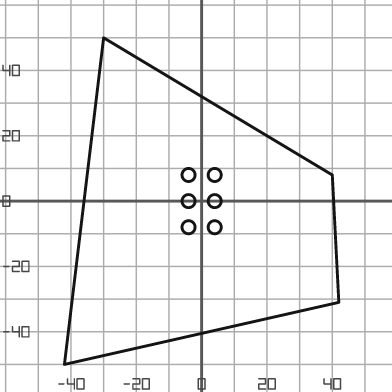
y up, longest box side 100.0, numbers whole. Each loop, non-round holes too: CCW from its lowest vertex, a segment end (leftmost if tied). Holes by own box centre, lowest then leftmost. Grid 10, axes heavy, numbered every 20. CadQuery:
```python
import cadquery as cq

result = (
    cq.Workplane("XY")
    .moveTo(-42.0, -50.0)
    .lineTo(42.0, -31.0)
    .lineTo(40.0, 8.0)
    .lineTo(-30.0, 50.0)
    .close()
    .moveTo(-4.0, -8.0)
    .circle(2.0)
    .moveTo(4.0, -8.0)
    .circle(2.0)
    .moveTo(-4.0, 0.0)
    .circle(2.0)
    .moveTo(4.0, 0.0)
    .circle(2.0)
    .moveTo(-4.0, 8.0)
    .circle(2.0)
    .moveTo(4.0, 8.0)
    .circle(2.0)
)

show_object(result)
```